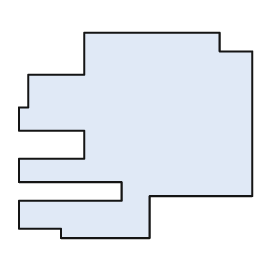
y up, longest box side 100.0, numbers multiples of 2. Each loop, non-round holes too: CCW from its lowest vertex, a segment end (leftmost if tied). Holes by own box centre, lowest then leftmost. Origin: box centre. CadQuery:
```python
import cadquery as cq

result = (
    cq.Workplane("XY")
    .moveTo(-32.0, -44.0)
    .lineTo(6.0, -44.0)
    .lineTo(6.0, -26.0)
    .lineTo(50.0, -26.0)
    .lineTo(50.0, 36.0)
    .lineTo(36.0, 36.0)
    .lineTo(36.0, 44.0)
    .lineTo(-22.0, 44.0)
    .lineTo(-22.0, 26.0)
    .lineTo(-46.0, 26.0)
    .lineTo(-46.0, 12.0)
    .lineTo(-50.0, 12.0)
    .lineTo(-50.0, 2.0)
    .lineTo(-22.0, 2.0)
    .lineTo(-22.0, -10.0)
    .lineTo(-50.0, -10.0)
    .lineTo(-50.0, -20.0)
    .lineTo(-6.0, -20.0)
    .lineTo(-6.0, -28.0)
    .lineTo(-50.0, -28.0)
    .lineTo(-50.0, -40.0)
    .lineTo(-32.0, -40.0)
    .close()
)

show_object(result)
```